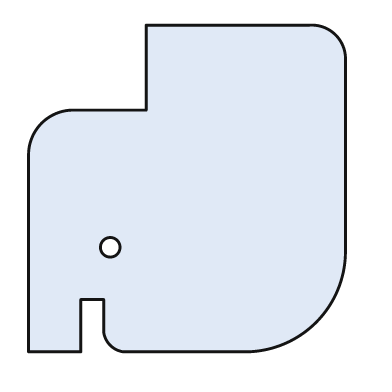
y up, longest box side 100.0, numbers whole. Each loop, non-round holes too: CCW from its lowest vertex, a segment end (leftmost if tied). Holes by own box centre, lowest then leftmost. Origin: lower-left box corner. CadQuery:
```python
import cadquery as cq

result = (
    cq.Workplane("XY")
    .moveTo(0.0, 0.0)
    .lineTo(16.0, 0.0)
    .lineTo(16.0, 16.0)
    .lineTo(23.0, 16.0)
    .lineTo(23.0, 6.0)
    .threePointArc((25.0, 2.0), (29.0, 0.0))
    .lineTo(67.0, 0.0)
    .threePointArc((88.0, 9.0), (97.0, 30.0))
    .lineTo(97.0, 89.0)
    .threePointArc((94.0, 97.0), (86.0, 100.0))
    .lineTo(36.0, 100.0)
    .lineTo(36.0, 74.0)
    .lineTo(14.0, 74.0)
    .threePointArc((4.0, 70.0), (0.0, 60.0))
    .close()
    .moveTo(25.0, 32.0)
    .circle(3.0)
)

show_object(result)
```